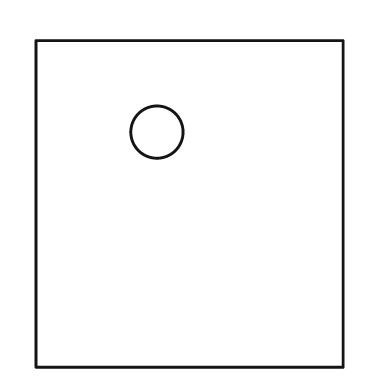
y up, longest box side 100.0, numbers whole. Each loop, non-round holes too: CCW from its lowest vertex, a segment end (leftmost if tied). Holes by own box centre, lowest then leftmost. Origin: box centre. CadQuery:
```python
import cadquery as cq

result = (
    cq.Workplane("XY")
    .moveTo(-47.0, -50.0)
    .lineTo(47.0, -50.0)
    .lineTo(47.0, 50.0)
    .lineTo(-47.0, 50.0)
    .close()
    .moveTo(-10.0, 22.0)
    .circle(8.0)
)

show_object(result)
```